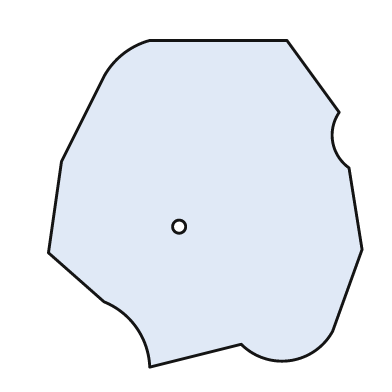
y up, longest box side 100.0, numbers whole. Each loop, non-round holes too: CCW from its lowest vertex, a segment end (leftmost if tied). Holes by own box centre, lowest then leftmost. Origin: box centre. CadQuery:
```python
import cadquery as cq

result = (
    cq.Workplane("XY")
    .moveTo(-17.0, -50.0)
    .lineTo(11.0, -43.0)
    .threePointArc((26.0, -48.0), (39.0, -39.0))
    .lineTo(48.0, -14.0)
    .lineTo(44.0, 11.0)
    .threePointArc((39.0, 19.0), (41.0, 28.0))
    .lineTo(25.0, 50.0)
    .lineTo(-17.0, 50.0)
    .threePointArc((-25.0, 46.0), (-31.0, 39.0))
    .lineTo(-44.0, 13.0)
    .lineTo(-48.0, -15.0)
    .lineTo(-31.0, -30.0)
    .threePointArc((-21.0, -38.0), (-17.0, -50.0))
    .close()
    .moveTo(-8.0, -7.0)
    .circle(2.0)
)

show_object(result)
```